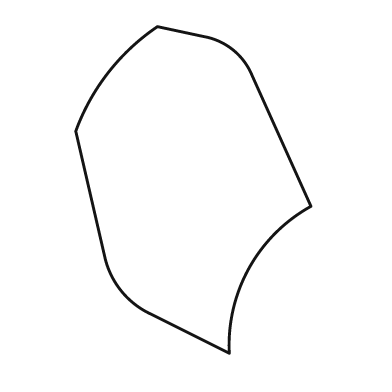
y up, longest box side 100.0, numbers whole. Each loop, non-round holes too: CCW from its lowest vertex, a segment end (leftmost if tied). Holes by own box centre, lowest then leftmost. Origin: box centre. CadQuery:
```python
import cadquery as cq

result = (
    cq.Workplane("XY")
    .moveTo(11.0, -50.0)
    .threePointArc((17.0, -24.0), (36.0, -5.0))
    .lineTo(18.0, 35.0)
    .threePointArc((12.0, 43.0), (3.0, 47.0))
    .lineTo(-11.0, 50.0)
    .threePointArc((-26.0, 36.0), (-36.0, 18.0))
    .lineTo(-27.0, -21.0)
    .threePointArc((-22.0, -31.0), (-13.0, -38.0))
    .close()
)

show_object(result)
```